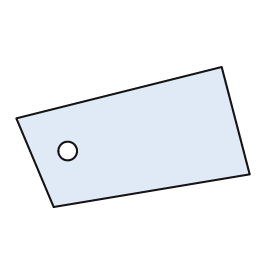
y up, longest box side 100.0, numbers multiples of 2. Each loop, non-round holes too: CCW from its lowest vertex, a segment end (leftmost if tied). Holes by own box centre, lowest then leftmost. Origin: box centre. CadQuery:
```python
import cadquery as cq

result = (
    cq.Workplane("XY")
    .moveTo(-34.0, -30.0)
    .lineTo(50.0, -16.0)
    .lineTo(38.0, 30.0)
    .lineTo(-50.0, 8.0)
    .close()
    .moveTo(-28.0, -6.0)
    .circle(4.0)
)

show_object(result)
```